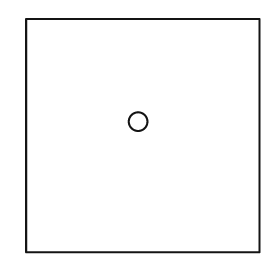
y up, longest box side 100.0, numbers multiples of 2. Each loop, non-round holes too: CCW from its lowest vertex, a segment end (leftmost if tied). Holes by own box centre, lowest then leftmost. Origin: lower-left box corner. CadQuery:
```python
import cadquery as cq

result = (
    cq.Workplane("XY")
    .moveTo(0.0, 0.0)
    .lineTo(100.0, 0.0)
    .lineTo(100.0, 100.0)
    .lineTo(0.0, 100.0)
    .close()
    .moveTo(48.0, 56.0)
    .circle(4.0)
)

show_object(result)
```